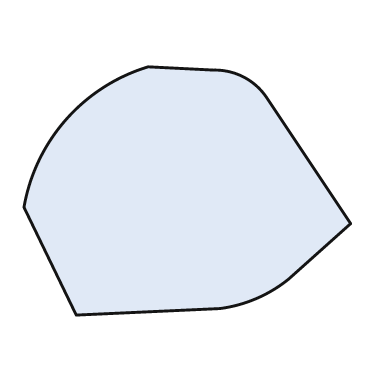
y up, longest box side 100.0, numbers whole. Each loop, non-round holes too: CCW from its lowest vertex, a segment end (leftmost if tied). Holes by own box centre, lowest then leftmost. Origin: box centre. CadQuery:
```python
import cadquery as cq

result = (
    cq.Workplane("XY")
    .moveTo(-34.0, -38.0)
    .lineTo(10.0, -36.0)
    .threePointArc((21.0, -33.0), (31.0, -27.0))
    .lineTo(50.0, -10.0)
    .lineTo(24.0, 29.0)
    .threePointArc((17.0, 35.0), (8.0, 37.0))
    .lineTo(-12.0, 38.0)
    .threePointArc((-37.0, 22.0), (-50.0, -5.0))
    .close()
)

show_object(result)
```